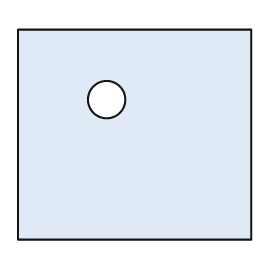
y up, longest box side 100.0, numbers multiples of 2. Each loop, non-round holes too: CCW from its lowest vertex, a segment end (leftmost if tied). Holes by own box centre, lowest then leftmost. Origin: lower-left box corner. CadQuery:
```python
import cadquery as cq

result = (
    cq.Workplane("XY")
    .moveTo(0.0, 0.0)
    .lineTo(100.0, 0.0)
    .lineTo(100.0, 90.0)
    .lineTo(0.0, 90.0)
    .close()
    .moveTo(38.0, 60.0)
    .circle(8.0)
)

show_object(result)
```